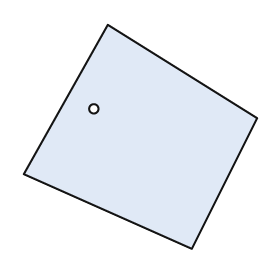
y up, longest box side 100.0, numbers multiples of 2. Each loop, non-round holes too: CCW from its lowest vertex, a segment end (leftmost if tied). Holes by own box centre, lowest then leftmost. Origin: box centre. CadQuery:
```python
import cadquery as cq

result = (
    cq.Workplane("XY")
    .moveTo(22.0, -48.0)
    .lineTo(50.0, 8.0)
    .lineTo(-14.0, 48.0)
    .lineTo(-50.0, -16.0)
    .close()
    .moveTo(-20.0, 12.0)
    .circle(2.0)
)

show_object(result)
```